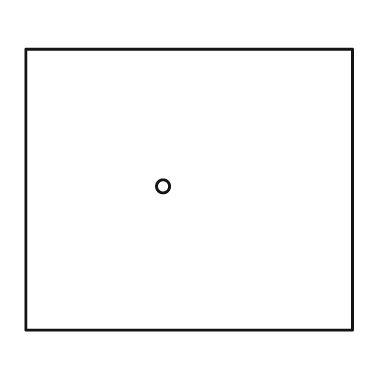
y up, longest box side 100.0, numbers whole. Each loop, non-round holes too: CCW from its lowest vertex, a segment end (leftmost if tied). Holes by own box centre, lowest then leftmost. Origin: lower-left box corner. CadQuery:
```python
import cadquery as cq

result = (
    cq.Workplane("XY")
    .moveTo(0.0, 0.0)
    .lineTo(100.0, 0.0)
    .lineTo(100.0, 86.0)
    .lineTo(0.0, 86.0)
    .close()
    .moveTo(42.0, 44.0)
    .circle(2.0)
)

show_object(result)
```